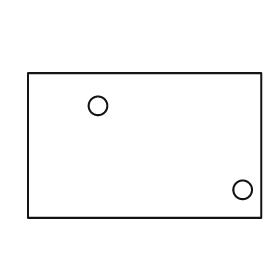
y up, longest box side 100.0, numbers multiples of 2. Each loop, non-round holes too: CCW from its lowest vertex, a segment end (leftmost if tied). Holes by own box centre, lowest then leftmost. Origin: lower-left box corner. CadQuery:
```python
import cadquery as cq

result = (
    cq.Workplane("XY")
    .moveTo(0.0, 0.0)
    .lineTo(100.0, 0.0)
    .lineTo(100.0, 62.0)
    .lineTo(0.0, 62.0)
    .close()
    .moveTo(92.0, 12.0)
    .circle(4.0)
    .moveTo(30.0, 48.0)
    .circle(4.0)
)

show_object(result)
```